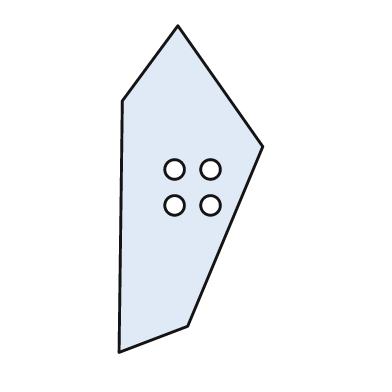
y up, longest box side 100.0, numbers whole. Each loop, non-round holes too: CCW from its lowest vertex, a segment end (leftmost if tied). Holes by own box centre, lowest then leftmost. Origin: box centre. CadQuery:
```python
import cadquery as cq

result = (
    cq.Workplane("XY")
    .moveTo(-22.0, -50.0)
    .lineTo(-1.0, -42.0)
    .lineTo(22.0, 13.0)
    .lineTo(-4.0, 50.0)
    .lineTo(-21.0, 27.0)
    .close()
    .moveTo(-5.0, -5.0)
    .circle(3.0)
    .moveTo(6.0, -5.0)
    .circle(3.0)
    .moveTo(-5.0, 6.0)
    .circle(3.0)
    .moveTo(6.0, 6.0)
    .circle(3.0)
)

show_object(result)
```